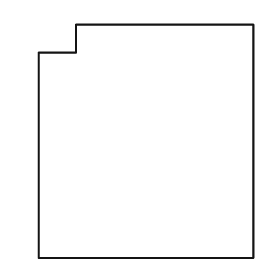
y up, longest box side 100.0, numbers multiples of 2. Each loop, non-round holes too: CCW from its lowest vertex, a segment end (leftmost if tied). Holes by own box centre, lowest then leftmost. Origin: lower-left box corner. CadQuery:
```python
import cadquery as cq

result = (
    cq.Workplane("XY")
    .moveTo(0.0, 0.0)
    .lineTo(92.0, 0.0)
    .lineTo(92.0, 100.0)
    .lineTo(16.0, 100.0)
    .lineTo(16.0, 88.0)
    .lineTo(0.0, 88.0)
    .close()
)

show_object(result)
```